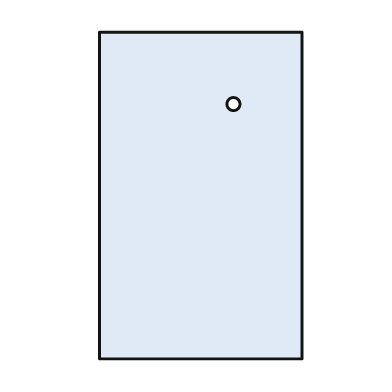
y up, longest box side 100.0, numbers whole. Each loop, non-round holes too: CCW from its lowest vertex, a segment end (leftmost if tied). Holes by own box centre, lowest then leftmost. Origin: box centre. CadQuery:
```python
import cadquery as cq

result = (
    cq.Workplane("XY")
    .moveTo(-31.0, -50.0)
    .lineTo(31.0, -50.0)
    .lineTo(31.0, 50.0)
    .lineTo(-31.0, 50.0)
    .close()
    .moveTo(10.0, 28.0)
    .circle(2.0)
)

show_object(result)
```